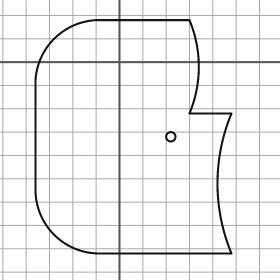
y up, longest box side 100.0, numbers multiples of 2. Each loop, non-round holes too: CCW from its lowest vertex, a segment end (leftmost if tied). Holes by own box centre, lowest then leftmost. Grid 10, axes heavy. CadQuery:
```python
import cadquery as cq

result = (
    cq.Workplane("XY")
    .moveTo(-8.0, -82.0)
    .lineTo(48.0, -82.0)
    .threePointArc((42.0, -52.0), (48.0, -22.0))
    .lineTo(30.0, -22.0)
    .threePointArc((34.0, -2.0), (30.0, 18.0))
    .lineTo(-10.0, 18.0)
    .threePointArc((-28.0, 10.0), (-36.0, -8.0))
    .lineTo(-36.0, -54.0)
    .threePointArc((-28.0, -74.0), (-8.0, -82.0))
    .close()
    .moveTo(22.0, -32.0)
    .circle(2.0)
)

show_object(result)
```